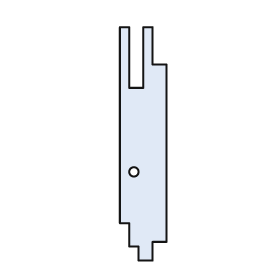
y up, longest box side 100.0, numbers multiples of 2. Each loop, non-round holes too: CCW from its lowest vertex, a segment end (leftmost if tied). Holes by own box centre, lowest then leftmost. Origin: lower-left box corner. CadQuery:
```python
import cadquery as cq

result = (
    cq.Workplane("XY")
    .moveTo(8.0, 0.0)
    .lineTo(14.0, 0.0)
    .lineTo(14.0, 8.0)
    .lineTo(20.0, 8.0)
    .lineTo(20.0, 84.0)
    .lineTo(14.0, 84.0)
    .lineTo(14.0, 100.0)
    .lineTo(10.0, 100.0)
    .lineTo(10.0, 74.0)
    .lineTo(4.0, 74.0)
    .lineTo(4.0, 100.0)
    .lineTo(0.0, 100.0)
    .lineTo(0.0, 16.0)
    .lineTo(4.0, 16.0)
    .lineTo(4.0, 6.0)
    .lineTo(8.0, 6.0)
    .close()
    .moveTo(6.0, 38.0)
    .circle(2.0)
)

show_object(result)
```